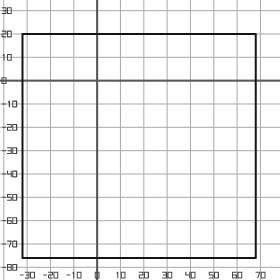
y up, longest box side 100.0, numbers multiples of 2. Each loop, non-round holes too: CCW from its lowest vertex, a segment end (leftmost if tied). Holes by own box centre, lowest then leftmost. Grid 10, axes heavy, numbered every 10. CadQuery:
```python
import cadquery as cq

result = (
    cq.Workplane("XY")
    .moveTo(-32.0, -76.0)
    .lineTo(68.0, -76.0)
    .lineTo(68.0, 20.0)
    .lineTo(-32.0, 20.0)
    .close()
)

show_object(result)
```